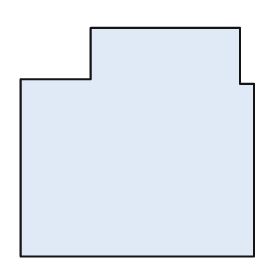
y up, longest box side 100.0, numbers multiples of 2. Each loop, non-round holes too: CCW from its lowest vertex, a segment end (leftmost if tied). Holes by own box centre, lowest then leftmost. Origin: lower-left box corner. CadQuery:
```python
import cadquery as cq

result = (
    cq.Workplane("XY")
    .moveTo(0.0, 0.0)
    .lineTo(100.0, 0.0)
    .lineTo(100.0, 74.0)
    .lineTo(94.0, 74.0)
    .lineTo(94.0, 98.0)
    .lineTo(30.0, 98.0)
    .lineTo(30.0, 76.0)
    .lineTo(0.0, 76.0)
    .close()
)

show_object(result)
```